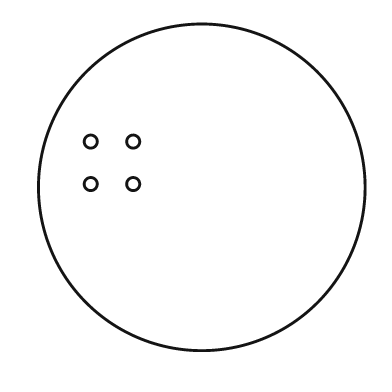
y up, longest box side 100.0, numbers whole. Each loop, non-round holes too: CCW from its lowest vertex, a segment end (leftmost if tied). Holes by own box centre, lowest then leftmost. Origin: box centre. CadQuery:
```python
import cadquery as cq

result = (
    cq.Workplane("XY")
    .moveTo(0.0, 0.0)
    .circle(50.0)
    .moveTo(-34.0, 1.0)
    .circle(2.0)
    .moveTo(-21.0, 1.0)
    .circle(2.0)
    .moveTo(-34.0, 14.0)
    .circle(2.0)
    .moveTo(-21.0, 14.0)
    .circle(2.0)
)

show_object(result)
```